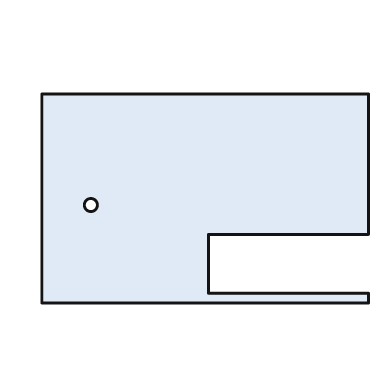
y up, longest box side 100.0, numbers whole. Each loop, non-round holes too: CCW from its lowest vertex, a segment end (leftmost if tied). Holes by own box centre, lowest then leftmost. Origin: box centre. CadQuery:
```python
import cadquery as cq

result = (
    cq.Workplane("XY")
    .moveTo(-50.0, -32.0)
    .lineTo(50.0, -32.0)
    .lineTo(50.0, -29.0)
    .lineTo(1.0, -29.0)
    .lineTo(1.0, -11.0)
    .lineTo(50.0, -11.0)
    .lineTo(50.0, 32.0)
    .lineTo(-50.0, 32.0)
    .close()
    .moveTo(-35.0, -2.0)
    .circle(2.0)
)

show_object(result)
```